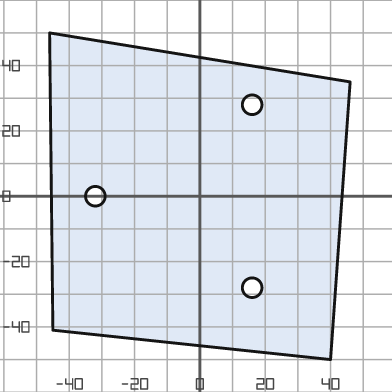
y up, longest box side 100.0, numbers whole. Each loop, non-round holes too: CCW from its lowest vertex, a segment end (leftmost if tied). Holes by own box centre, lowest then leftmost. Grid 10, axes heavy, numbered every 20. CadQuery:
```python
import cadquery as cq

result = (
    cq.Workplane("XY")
    .moveTo(40.0, -50.0)
    .lineTo(46.0, 35.0)
    .lineTo(-46.0, 50.0)
    .lineTo(-45.0, -41.0)
    .close()
    .moveTo(16.0, -28.0)
    .circle(3.0)
    .moveTo(-32.0, 0.0)
    .circle(3.0)
    .moveTo(16.0, 28.0)
    .circle(3.0)
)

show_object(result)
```